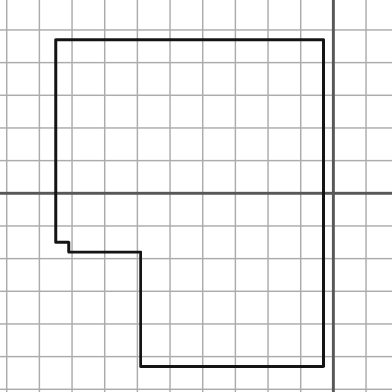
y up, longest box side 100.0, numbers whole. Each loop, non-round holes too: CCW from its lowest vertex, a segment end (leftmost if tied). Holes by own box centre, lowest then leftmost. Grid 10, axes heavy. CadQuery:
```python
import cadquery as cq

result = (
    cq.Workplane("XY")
    .moveTo(-59.0, -53.0)
    .lineTo(-3.0, -53.0)
    .lineTo(-3.0, 47.0)
    .lineTo(-85.0, 47.0)
    .lineTo(-85.0, -15.0)
    .lineTo(-81.0, -15.0)
    .lineTo(-81.0, -18.0)
    .lineTo(-59.0, -18.0)
    .close()
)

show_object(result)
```